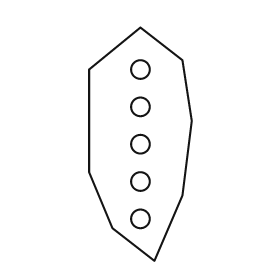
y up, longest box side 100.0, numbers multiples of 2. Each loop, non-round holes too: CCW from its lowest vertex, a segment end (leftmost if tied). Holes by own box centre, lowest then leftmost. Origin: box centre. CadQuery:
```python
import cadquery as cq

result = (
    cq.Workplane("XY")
    .moveTo(6.0, -50.0)
    .lineTo(18.0, -22.0)
    .lineTo(22.0, 10.0)
    .lineTo(18.0, 36.0)
    .lineTo(0.0, 50.0)
    .lineTo(-22.0, 32.0)
    .lineTo(-22.0, -12.0)
    .lineTo(-12.0, -36.0)
    .close()
    .moveTo(0.0, -32.0)
    .circle(4.0)
    .moveTo(0.0, -16.0)
    .circle(4.0)
    .moveTo(0.0, 0.0)
    .circle(4.0)
    .moveTo(0.0, 16.0)
    .circle(4.0)
    .moveTo(0.0, 32.0)
    .circle(4.0)
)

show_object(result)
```